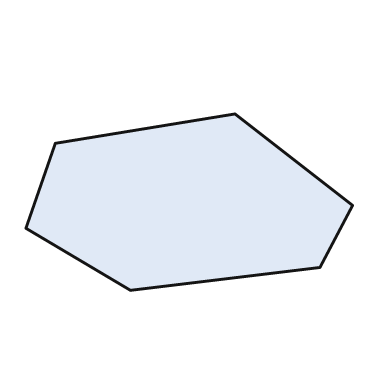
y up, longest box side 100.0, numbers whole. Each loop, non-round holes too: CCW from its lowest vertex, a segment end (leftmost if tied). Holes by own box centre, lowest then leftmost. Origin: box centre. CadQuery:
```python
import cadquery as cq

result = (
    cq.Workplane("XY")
    .moveTo(-18.0, -27.0)
    .lineTo(40.0, -20.0)
    .lineTo(50.0, -1.0)
    .lineTo(14.0, 27.0)
    .lineTo(-41.0, 18.0)
    .lineTo(-50.0, -8.0)
    .close()
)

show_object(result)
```